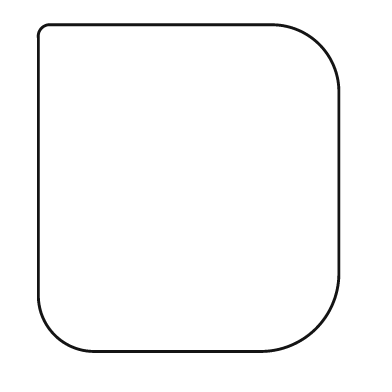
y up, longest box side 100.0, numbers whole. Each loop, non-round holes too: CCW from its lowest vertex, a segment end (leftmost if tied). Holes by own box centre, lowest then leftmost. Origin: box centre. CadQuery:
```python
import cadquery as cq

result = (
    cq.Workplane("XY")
    .moveTo(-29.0, -50.0)
    .lineTo(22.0, -50.0)
    .threePointArc((39.0, -43.0), (46.0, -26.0))
    .lineTo(46.0, 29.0)
    .threePointArc((40.0, 44.0), (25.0, 50.0))
    .lineTo(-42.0, 50.0)
    .threePointArc((-45.0, 49.0), (-46.0, 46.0))
    .lineTo(-46.0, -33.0)
    .threePointArc((-41.0, -45.0), (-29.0, -50.0))
    .close()
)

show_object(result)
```